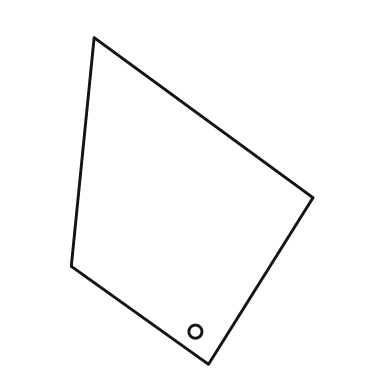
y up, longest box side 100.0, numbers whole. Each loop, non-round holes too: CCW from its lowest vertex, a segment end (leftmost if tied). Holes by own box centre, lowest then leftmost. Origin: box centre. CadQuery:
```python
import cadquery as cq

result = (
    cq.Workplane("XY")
    .moveTo(5.0, -50.0)
    .lineTo(37.0, 1.0)
    .lineTo(-30.0, 50.0)
    .lineTo(-37.0, -20.0)
    .close()
    .moveTo(1.0, -40.0)
    .circle(2.0)
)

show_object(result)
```